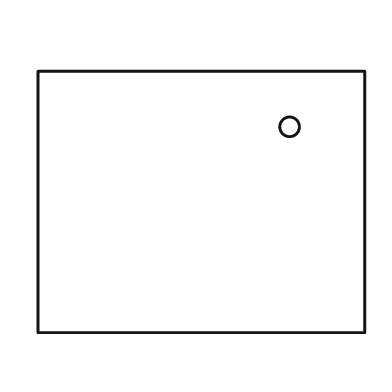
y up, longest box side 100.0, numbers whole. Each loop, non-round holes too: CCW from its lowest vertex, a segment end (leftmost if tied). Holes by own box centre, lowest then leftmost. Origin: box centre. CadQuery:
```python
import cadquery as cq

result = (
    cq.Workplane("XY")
    .moveTo(-50.0, -40.0)
    .lineTo(50.0, -40.0)
    .lineTo(50.0, 40.0)
    .lineTo(-50.0, 40.0)
    .close()
    .moveTo(27.0, 23.0)
    .circle(3.0)
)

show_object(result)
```